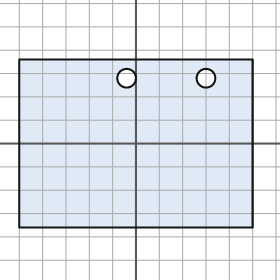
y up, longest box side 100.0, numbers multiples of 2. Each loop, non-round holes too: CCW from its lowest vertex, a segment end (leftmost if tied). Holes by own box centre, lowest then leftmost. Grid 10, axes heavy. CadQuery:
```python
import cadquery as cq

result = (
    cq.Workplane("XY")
    .moveTo(-50.0, -36.0)
    .lineTo(50.0, -36.0)
    .lineTo(50.0, 36.0)
    .lineTo(-50.0, 36.0)
    .close()
    .moveTo(-4.0, 28.0)
    .circle(4.0)
    .moveTo(30.0, 28.0)
    .circle(4.0)
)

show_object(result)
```